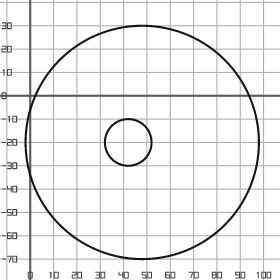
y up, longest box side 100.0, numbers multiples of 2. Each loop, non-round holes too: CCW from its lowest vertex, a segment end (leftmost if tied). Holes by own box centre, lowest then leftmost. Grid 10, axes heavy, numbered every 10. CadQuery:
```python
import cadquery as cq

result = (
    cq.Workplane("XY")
    .moveTo(48.0, -20.0)
    .circle(50.0)
    .moveTo(42.0, -20.0)
    .circle(10.0)
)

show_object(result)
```